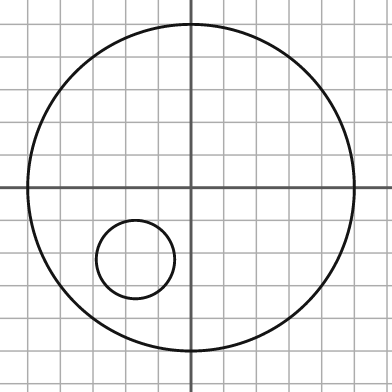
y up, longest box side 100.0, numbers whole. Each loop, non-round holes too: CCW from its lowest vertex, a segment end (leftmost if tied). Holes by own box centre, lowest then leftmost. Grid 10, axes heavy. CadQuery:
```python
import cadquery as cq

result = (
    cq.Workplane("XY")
    .moveTo(0.0, 0.0)
    .circle(50.0)
    .moveTo(-17.0, -22.0)
    .circle(12.0)
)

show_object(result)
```